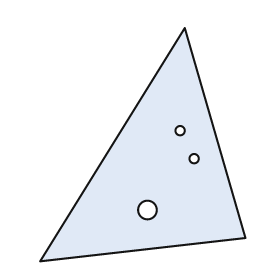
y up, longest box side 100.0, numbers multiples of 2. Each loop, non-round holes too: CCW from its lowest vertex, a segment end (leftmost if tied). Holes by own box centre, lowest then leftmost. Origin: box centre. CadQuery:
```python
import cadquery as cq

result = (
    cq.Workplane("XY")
    .moveTo(-44.0, -50.0)
    .lineTo(44.0, -40.0)
    .lineTo(18.0, 50.0)
    .close()
    .moveTo(2.0, -28.0)
    .circle(4.0)
    .moveTo(22.0, -6.0)
    .circle(2.0)
    .moveTo(16.0, 6.0)
    .circle(2.0)
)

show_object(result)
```